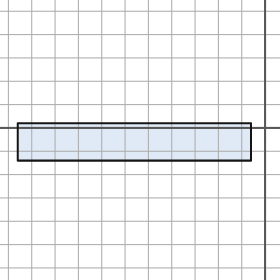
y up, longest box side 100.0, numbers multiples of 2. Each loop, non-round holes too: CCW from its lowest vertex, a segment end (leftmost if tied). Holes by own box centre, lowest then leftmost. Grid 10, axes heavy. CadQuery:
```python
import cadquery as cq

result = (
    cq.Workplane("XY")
    .moveTo(-106.0, -14.0)
    .lineTo(-6.0, -14.0)
    .lineTo(-6.0, 2.0)
    .lineTo(-106.0, 2.0)
    .close()
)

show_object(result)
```